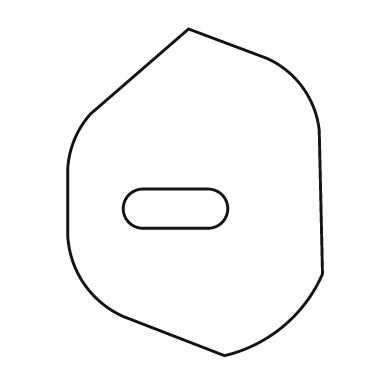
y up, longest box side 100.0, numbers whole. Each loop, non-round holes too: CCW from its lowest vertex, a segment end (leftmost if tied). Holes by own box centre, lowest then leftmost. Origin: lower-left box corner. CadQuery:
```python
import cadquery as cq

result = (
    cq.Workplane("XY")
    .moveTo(48.0, 0.0)
    .threePointArc((66.0, 9.0), (78.0, 25.0))
    .lineTo(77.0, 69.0)
    .threePointArc((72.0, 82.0), (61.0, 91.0))
    .lineTo(37.0, 100.0)
    .lineTo(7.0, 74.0)
    .threePointArc((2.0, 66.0), (0.0, 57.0))
    .lineTo(0.0, 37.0)
    .threePointArc((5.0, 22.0), (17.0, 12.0))
    .close()
    .moveTo(23.0, 39.0)
    .lineTo(43.0, 39.0)
    .threePointArc((49.0, 45.0), (43.0, 51.0))
    .lineTo(23.0, 51.0)
    .threePointArc((17.0, 45.0), (23.0, 39.0))
    .close()
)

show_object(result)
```